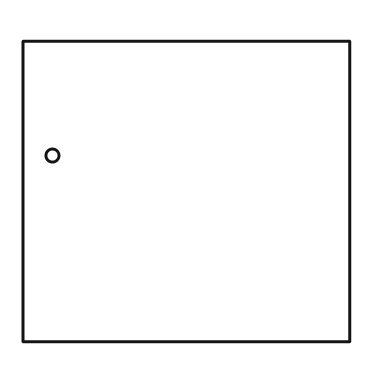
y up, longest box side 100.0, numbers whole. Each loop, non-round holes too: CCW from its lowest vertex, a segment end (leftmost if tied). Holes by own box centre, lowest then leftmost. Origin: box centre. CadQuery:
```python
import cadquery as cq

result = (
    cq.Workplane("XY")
    .moveTo(-50.0, -46.0)
    .lineTo(50.0, -46.0)
    .lineTo(50.0, 46.0)
    .lineTo(-50.0, 46.0)
    .close()
    .moveTo(-41.0, 11.0)
    .circle(2.0)
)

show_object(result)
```